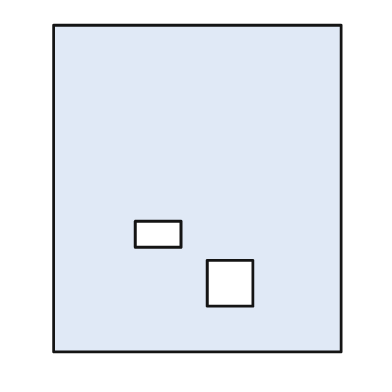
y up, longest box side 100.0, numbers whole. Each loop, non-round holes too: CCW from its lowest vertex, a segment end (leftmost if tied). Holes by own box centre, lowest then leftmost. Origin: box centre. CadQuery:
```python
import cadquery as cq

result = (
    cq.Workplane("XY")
    .moveTo(-44.0, -50.0)
    .lineTo(44.0, -50.0)
    .lineTo(44.0, 50.0)
    .lineTo(-44.0, 50.0)
    .close()
    .moveTo(3.0, -36.0)
    .lineTo(17.0, -36.0)
    .lineTo(17.0, -22.0)
    .lineTo(3.0, -22.0)
    .close()
    .moveTo(-19.0, -18.0)
    .lineTo(-5.0, -18.0)
    .lineTo(-5.0, -10.0)
    .lineTo(-19.0, -10.0)
    .close()
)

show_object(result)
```